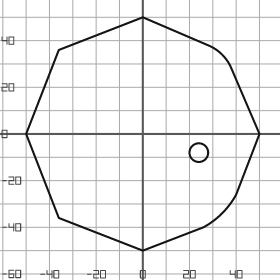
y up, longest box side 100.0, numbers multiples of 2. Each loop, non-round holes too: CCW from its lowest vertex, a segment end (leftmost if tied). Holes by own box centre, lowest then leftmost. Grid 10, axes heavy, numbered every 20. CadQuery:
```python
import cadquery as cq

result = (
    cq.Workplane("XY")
    .moveTo(0.0, -50.0)
    .lineTo(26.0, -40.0)
    .threePointArc((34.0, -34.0), (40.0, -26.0))
    .lineTo(50.0, 0.0)
    .lineTo(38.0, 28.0)
    .threePointArc((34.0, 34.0), (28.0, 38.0))
    .lineTo(0.0, 50.0)
    .lineTo(-36.0, 36.0)
    .lineTo(-50.0, 0.0)
    .lineTo(-36.0, -36.0)
    .close()
    .moveTo(24.0, -8.0)
    .circle(4.0)
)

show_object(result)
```